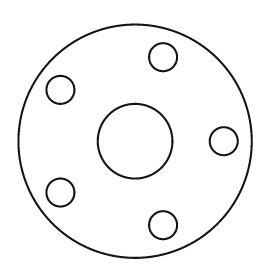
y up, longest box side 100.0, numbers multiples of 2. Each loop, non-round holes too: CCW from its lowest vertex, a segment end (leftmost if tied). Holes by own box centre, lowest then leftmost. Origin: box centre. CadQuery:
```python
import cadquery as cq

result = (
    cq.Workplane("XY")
    .moveTo(0.0, 0.0)
    .circle(50.0)
    .moveTo(12.0, -36.0)
    .circle(6.0)
    .moveTo(-32.0, -22.0)
    .circle(6.0)
    .moveTo(0.0, 0.0)
    .circle(16.0)
    .moveTo(38.0, 0.0)
    .circle(6.0)
    .moveTo(-32.0, 22.0)
    .circle(6.0)
    .moveTo(12.0, 36.0)
    .circle(6.0)
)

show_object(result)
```